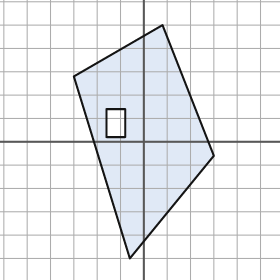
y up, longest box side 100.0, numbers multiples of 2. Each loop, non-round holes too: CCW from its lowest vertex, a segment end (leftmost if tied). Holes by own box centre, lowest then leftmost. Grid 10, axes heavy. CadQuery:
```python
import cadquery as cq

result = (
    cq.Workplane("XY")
    .moveTo(-6.0, -50.0)
    .lineTo(30.0, -6.0)
    .lineTo(8.0, 50.0)
    .lineTo(-30.0, 28.0)
    .close()
    .moveTo(-16.0, 2.0)
    .lineTo(-8.0, 2.0)
    .lineTo(-8.0, 14.0)
    .lineTo(-16.0, 14.0)
    .close()
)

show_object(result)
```